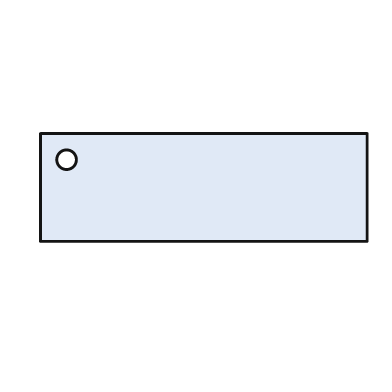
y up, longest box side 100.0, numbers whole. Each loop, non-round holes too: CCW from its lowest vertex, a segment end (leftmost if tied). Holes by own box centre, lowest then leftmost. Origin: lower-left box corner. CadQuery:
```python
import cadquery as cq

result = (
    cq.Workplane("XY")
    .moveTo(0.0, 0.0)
    .lineTo(100.0, 0.0)
    .lineTo(100.0, 33.0)
    .lineTo(0.0, 33.0)
    .close()
    .moveTo(8.0, 25.0)
    .circle(3.0)
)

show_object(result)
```